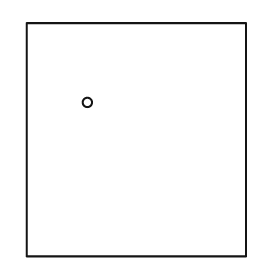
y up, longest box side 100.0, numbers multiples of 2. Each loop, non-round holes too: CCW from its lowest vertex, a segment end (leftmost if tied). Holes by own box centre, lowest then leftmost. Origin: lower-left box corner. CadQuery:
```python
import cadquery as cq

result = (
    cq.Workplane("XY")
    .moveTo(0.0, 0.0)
    .lineTo(94.0, 0.0)
    .lineTo(94.0, 100.0)
    .lineTo(0.0, 100.0)
    .close()
    .moveTo(26.0, 66.0)
    .circle(2.0)
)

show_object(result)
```